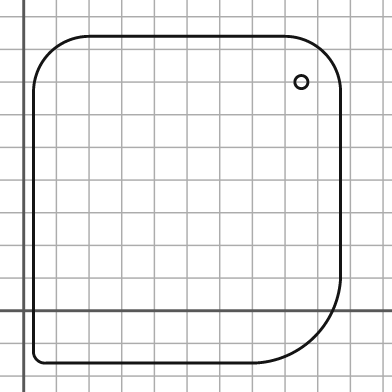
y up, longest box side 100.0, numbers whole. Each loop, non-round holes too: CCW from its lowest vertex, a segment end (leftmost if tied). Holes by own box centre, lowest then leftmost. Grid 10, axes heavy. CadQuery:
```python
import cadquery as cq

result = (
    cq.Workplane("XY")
    .moveTo(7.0, -16.0)
    .lineTo(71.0, -16.0)
    .threePointArc((89.0, -8.0), (97.0, 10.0))
    .lineTo(97.0, 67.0)
    .threePointArc((92.0, 79.0), (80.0, 84.0))
    .lineTo(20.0, 84.0)
    .threePointArc((8.0, 79.0), (3.0, 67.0))
    .lineTo(3.0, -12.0)
    .threePointArc((4.0, -15.0), (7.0, -16.0))
    .close()
    .moveTo(85.0, 70.0)
    .circle(2.0)
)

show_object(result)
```